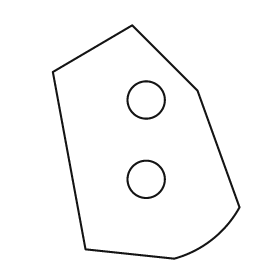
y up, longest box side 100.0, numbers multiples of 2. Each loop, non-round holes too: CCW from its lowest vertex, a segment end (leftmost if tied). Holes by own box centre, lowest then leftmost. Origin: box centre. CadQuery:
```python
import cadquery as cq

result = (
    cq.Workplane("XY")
    .moveTo(12.0, -50.0)
    .threePointArc((28.0, -42.0), (40.0, -28.0))
    .lineTo(22.0, 22.0)
    .lineTo(-6.0, 50.0)
    .lineTo(-40.0, 30.0)
    .lineTo(-26.0, -46.0)
    .close()
    .moveTo(0.0, -16.0)
    .circle(8.0)
    .moveTo(0.0, 18.0)
    .circle(8.0)
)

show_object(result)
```